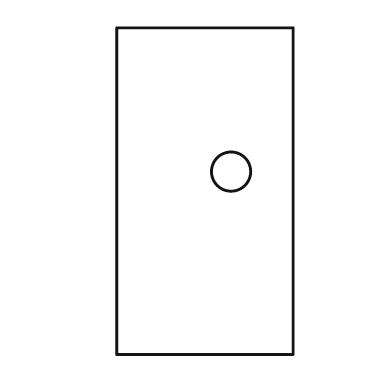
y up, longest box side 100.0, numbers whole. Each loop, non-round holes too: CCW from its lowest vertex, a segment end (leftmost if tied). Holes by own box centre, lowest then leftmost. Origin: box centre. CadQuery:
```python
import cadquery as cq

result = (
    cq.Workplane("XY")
    .moveTo(-27.0, -50.0)
    .lineTo(27.0, -50.0)
    .lineTo(27.0, 50.0)
    .lineTo(-27.0, 50.0)
    .close()
    .moveTo(8.0, 6.0)
    .circle(6.0)
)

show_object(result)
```